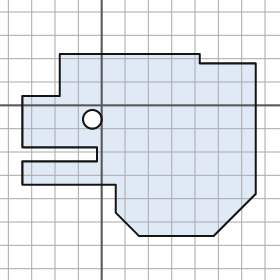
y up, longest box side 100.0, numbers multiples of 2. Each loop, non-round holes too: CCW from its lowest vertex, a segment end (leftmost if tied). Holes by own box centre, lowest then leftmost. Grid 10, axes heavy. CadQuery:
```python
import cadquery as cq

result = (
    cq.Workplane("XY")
    .moveTo(16.0, -56.0)
    .lineTo(48.0, -56.0)
    .lineTo(66.0, -38.0)
    .lineTo(66.0, 18.0)
    .lineTo(42.0, 18.0)
    .lineTo(42.0, 22.0)
    .lineTo(-18.0, 22.0)
    .lineTo(-18.0, 4.0)
    .lineTo(-34.0, 4.0)
    .lineTo(-34.0, -18.0)
    .lineTo(-2.0, -18.0)
    .lineTo(-2.0, -24.0)
    .lineTo(-34.0, -24.0)
    .lineTo(-34.0, -34.0)
    .lineTo(6.0, -34.0)
    .lineTo(6.0, -46.0)
    .close()
    .moveTo(-4.0, -6.0)
    .circle(4.0)
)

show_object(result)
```